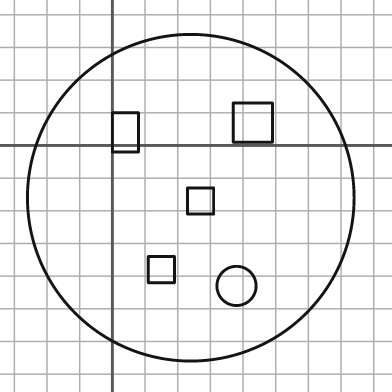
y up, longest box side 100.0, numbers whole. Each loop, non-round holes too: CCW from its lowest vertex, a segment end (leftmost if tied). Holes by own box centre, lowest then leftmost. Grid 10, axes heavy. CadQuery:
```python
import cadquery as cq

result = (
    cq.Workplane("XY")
    .moveTo(24.0, -16.0)
    .circle(50.0)
    .moveTo(38.0, -43.0)
    .circle(6.0)
    .moveTo(11.0, -42.0)
    .lineTo(19.0, -42.0)
    .lineTo(19.0, -34.0)
    .lineTo(11.0, -34.0)
    .close()
    .moveTo(23.0, -21.0)
    .lineTo(31.0, -21.0)
    .lineTo(31.0, -13.0)
    .lineTo(23.0, -13.0)
    .close()
    .moveTo(0.0, -2.0)
    .lineTo(8.0, -2.0)
    .lineTo(8.0, 10.0)
    .lineTo(0.0, 10.0)
    .close()
    .moveTo(37.0, 1.0)
    .lineTo(49.0, 1.0)
    .lineTo(49.0, 13.0)
    .lineTo(37.0, 13.0)
    .close()
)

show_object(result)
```